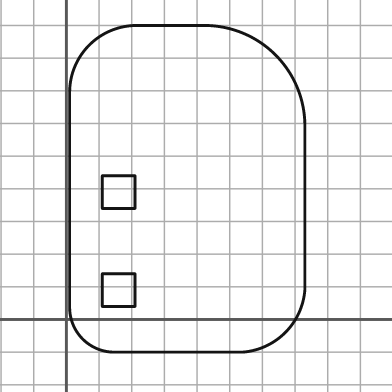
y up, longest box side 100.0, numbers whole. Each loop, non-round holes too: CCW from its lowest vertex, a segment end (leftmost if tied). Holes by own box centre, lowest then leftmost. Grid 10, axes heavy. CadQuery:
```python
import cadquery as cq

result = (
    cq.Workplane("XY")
    .moveTo(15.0, -10.0)
    .lineTo(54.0, -10.0)
    .threePointArc((67.0, -4.0), (73.0, 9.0))
    .lineTo(73.0, 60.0)
    .threePointArc((64.0, 81.0), (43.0, 90.0))
    .lineTo(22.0, 90.0)
    .threePointArc((7.0, 84.0), (1.0, 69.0))
    .lineTo(1.0, 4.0)
    .threePointArc((5.0, -6.0), (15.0, -10.0))
    .close()
    .moveTo(11.0, 4.0)
    .lineTo(21.0, 4.0)
    .lineTo(21.0, 14.0)
    .lineTo(11.0, 14.0)
    .close()
    .moveTo(11.0, 34.0)
    .lineTo(21.0, 34.0)
    .lineTo(21.0, 44.0)
    .lineTo(11.0, 44.0)
    .close()
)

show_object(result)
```